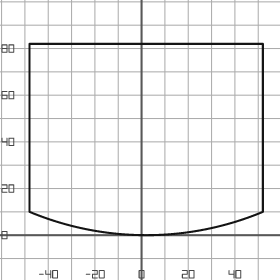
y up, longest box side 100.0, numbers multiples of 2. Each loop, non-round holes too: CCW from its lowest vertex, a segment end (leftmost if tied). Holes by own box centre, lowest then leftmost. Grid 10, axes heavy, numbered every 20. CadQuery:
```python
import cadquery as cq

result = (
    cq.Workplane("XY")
    .moveTo(-48.0, 10.0)
    .threePointArc((2.0, 0.0), (52.0, 10.0))
    .lineTo(52.0, 82.0)
    .lineTo(-48.0, 82.0)
    .close()
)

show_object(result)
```